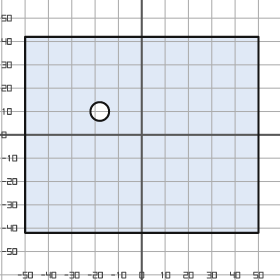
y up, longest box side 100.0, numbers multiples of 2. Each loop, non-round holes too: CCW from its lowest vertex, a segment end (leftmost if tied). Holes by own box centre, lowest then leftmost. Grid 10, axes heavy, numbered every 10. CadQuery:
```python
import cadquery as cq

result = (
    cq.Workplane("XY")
    .moveTo(-50.0, -42.0)
    .lineTo(50.0, -42.0)
    .lineTo(50.0, 42.0)
    .lineTo(-50.0, 42.0)
    .close()
    .moveTo(-18.0, 10.0)
    .circle(4.0)
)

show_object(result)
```